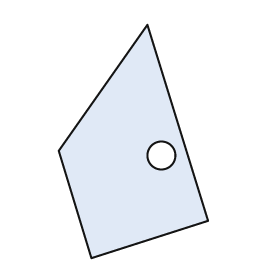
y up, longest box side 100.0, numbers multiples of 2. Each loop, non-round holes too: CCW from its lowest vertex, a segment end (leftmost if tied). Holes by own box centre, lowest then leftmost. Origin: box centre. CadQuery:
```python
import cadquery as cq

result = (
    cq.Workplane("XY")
    .moveTo(-18.0, -50.0)
    .lineTo(32.0, -34.0)
    .lineTo(6.0, 50.0)
    .lineTo(-32.0, -4.0)
    .close()
    .moveTo(12.0, -6.0)
    .circle(6.0)
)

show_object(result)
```